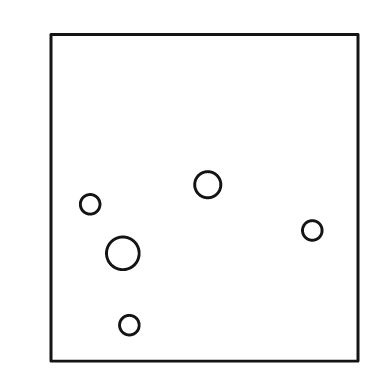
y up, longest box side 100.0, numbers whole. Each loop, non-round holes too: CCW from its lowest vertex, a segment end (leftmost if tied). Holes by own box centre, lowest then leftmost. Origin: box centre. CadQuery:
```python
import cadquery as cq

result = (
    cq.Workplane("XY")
    .moveTo(-47.0, -50.0)
    .lineTo(47.0, -50.0)
    .lineTo(47.0, 50.0)
    .lineTo(-47.0, 50.0)
    .close()
    .moveTo(-23.0, -39.0)
    .circle(3.0)
    .moveTo(-25.0, -17.0)
    .circle(5.0)
    .moveTo(33.0, -10.0)
    .circle(3.0)
    .moveTo(-35.0, -2.0)
    .circle(3.0)
    .moveTo(1.0, 4.0)
    .circle(4.0)
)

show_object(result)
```